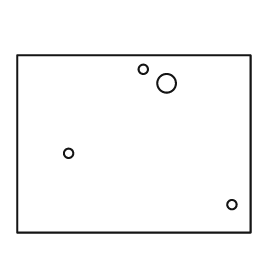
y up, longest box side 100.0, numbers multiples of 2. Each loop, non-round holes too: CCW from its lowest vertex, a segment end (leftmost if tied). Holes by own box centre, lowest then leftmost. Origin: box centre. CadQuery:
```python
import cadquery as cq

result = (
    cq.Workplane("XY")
    .moveTo(-50.0, -38.0)
    .lineTo(50.0, -38.0)
    .lineTo(50.0, 38.0)
    .lineTo(-50.0, 38.0)
    .close()
    .moveTo(42.0, -26.0)
    .circle(2.0)
    .moveTo(-28.0, -4.0)
    .circle(2.0)
    .moveTo(14.0, 26.0)
    .circle(4.0)
    .moveTo(4.0, 32.0)
    .circle(2.0)
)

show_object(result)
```